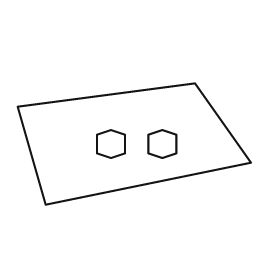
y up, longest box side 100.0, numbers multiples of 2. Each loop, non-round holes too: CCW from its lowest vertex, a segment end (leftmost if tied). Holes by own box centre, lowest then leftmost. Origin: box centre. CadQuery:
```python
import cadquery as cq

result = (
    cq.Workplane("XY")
    .moveTo(-38.0, -26.0)
    .lineTo(50.0, -8.0)
    .lineTo(26.0, 26.0)
    .lineTo(-50.0, 16.0)
    .close()
    .moveTo(-10.0, -6.0)
    .lineTo(-4.0, -4.0)
    .lineTo(-4.0, 4.0)
    .lineTo(-10.0, 6.0)
    .lineTo(-16.0, 4.0)
    .lineTo(-16.0, -4.0)
    .close()
    .moveTo(12.0, -6.0)
    .lineTo(18.0, -4.0)
    .lineTo(18.0, 4.0)
    .lineTo(12.0, 6.0)
    .lineTo(6.0, 4.0)
    .lineTo(6.0, -4.0)
    .close()
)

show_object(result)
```